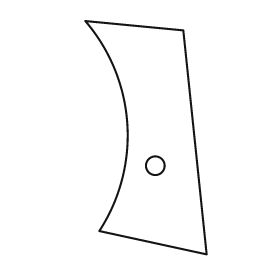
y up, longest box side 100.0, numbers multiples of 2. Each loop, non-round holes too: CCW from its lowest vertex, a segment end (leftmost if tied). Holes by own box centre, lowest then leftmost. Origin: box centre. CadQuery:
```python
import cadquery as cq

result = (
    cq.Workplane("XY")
    .moveTo(26.0, -50.0)
    .lineTo(16.0, 46.0)
    .lineTo(-26.0, 50.0)
    .threePointArc((-8.0, 6.0), (-20.0, -40.0))
    .close()
    .moveTo(4.0, -12.0)
    .circle(4.0)
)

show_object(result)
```